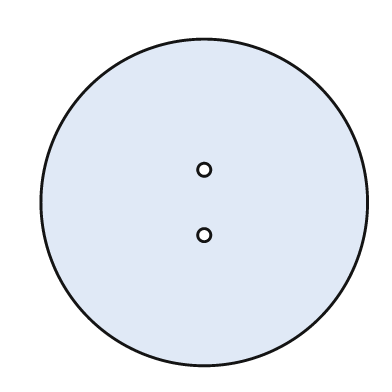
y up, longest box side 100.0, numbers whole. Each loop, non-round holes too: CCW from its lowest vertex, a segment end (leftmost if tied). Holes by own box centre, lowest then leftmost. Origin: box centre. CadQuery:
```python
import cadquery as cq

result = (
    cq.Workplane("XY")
    .moveTo(0.0, 0.0)
    .circle(50.0)
    .moveTo(0.0, -10.0)
    .circle(2.0)
    .moveTo(0.0, 10.0)
    .circle(2.0)
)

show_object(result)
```